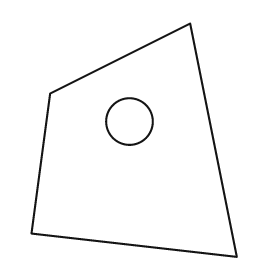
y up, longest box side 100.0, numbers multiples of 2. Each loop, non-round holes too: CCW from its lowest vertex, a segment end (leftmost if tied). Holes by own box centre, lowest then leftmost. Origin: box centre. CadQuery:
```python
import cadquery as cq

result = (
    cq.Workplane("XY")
    .moveTo(44.0, -50.0)
    .lineTo(24.0, 50.0)
    .lineTo(-36.0, 20.0)
    .lineTo(-44.0, -40.0)
    .close()
    .moveTo(-2.0, 8.0)
    .circle(10.0)
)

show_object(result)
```